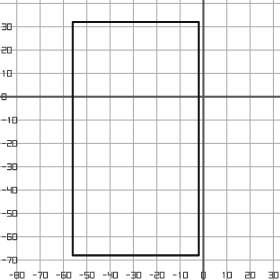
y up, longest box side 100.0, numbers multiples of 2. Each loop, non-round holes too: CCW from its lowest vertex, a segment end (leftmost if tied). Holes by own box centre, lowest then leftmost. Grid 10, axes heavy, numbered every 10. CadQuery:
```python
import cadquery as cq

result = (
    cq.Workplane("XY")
    .moveTo(-56.0, -68.0)
    .lineTo(-2.0, -68.0)
    .lineTo(-2.0, 32.0)
    .lineTo(-56.0, 32.0)
    .close()
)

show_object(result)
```